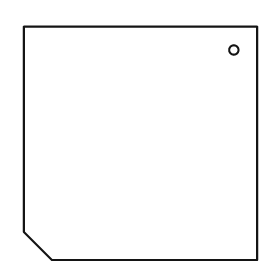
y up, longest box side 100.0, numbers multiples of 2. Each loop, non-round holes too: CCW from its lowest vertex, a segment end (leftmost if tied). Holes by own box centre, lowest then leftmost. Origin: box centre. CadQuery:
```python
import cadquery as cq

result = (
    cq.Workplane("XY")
    .moveTo(-38.0, -50.0)
    .lineTo(50.0, -50.0)
    .lineTo(50.0, 50.0)
    .lineTo(-50.0, 50.0)
    .lineTo(-50.0, -38.0)
    .close()
    .moveTo(40.0, 40.0)
    .circle(2.0)
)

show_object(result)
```